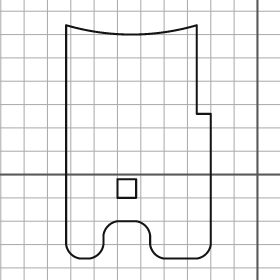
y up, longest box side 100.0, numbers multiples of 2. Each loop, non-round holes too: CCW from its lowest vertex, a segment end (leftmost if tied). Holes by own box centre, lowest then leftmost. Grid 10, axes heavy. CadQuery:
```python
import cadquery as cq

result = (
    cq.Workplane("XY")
    .moveTo(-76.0, -36.0)
    .lineTo(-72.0, -36.0)
    .threePointArc((-68.0, -34.0), (-66.0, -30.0))
    .lineTo(-66.0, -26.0)
    .threePointArc((-64.0, -22.0), (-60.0, -20.0))
    .lineTo(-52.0, -20.0)
    .threePointArc((-48.0, -22.0), (-46.0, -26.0))
    .lineTo(-46.0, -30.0)
    .threePointArc((-44.0, -34.0), (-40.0, -36.0))
    .lineTo(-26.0, -36.0)
    .threePointArc((-22.0, -34.0), (-20.0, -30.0))
    .lineTo(-20.0, 26.0)
    .lineTo(-26.0, 26.0)
    .lineTo(-26.0, 64.0)
    .threePointArc((-54.0, 60.0), (-82.0, 64.0))
    .lineTo(-82.0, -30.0)
    .threePointArc((-80.0, -34.0), (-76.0, -36.0))
    .close()
    .moveTo(-60.0, -10.0)
    .lineTo(-52.0, -10.0)
    .lineTo(-52.0, -2.0)
    .lineTo(-60.0, -2.0)
    .close()
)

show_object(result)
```